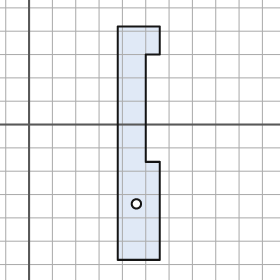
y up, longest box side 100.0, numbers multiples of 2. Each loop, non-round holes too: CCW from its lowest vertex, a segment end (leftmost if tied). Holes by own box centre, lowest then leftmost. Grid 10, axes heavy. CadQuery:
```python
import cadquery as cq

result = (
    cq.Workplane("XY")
    .moveTo(38.0, -58.0)
    .lineTo(56.0, -58.0)
    .lineTo(56.0, -16.0)
    .lineTo(50.0, -16.0)
    .lineTo(50.0, 30.0)
    .lineTo(56.0, 30.0)
    .lineTo(56.0, 42.0)
    .lineTo(38.0, 42.0)
    .close()
    .moveTo(46.0, -34.0)
    .circle(2.0)
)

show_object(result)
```